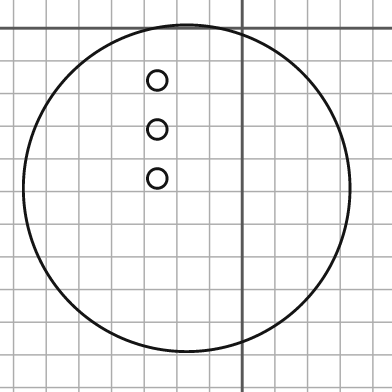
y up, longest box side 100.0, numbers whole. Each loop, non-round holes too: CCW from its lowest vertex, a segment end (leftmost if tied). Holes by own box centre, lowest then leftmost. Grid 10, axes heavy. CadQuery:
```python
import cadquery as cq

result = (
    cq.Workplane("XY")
    .moveTo(-17.0, -49.0)
    .circle(50.0)
    .moveTo(-26.0, -46.0)
    .circle(3.0)
    .moveTo(-26.0, -31.0)
    .circle(3.0)
    .moveTo(-26.0, -16.0)
    .circle(3.0)
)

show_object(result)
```